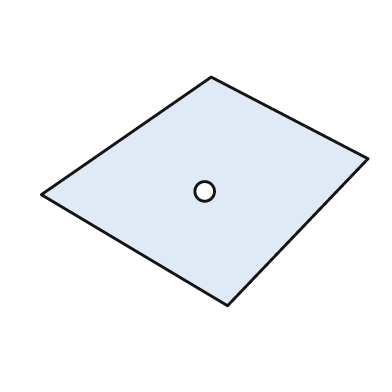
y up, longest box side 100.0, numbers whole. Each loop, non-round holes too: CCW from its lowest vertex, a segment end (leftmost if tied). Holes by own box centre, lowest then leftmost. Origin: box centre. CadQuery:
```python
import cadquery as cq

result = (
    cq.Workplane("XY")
    .moveTo(7.0, -35.0)
    .lineTo(50.0, 10.0)
    .lineTo(2.0, 35.0)
    .lineTo(-50.0, -1.0)
    .close()
    .moveTo(0.0, 0.0)
    .circle(3.0)
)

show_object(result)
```